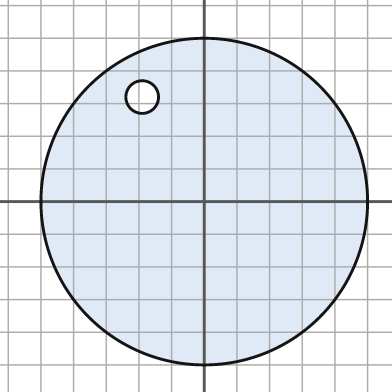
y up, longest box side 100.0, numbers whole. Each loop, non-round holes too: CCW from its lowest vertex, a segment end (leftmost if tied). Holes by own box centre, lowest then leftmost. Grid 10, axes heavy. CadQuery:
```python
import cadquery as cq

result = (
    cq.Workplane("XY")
    .moveTo(0.0, 0.0)
    .circle(50.0)
    .moveTo(-19.0, 32.0)
    .circle(5.0)
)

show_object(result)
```